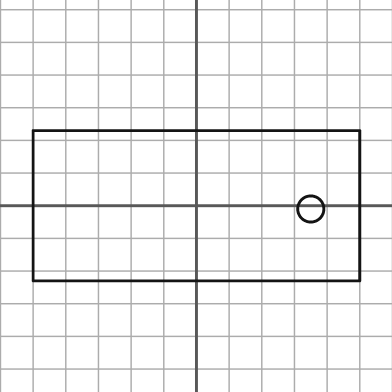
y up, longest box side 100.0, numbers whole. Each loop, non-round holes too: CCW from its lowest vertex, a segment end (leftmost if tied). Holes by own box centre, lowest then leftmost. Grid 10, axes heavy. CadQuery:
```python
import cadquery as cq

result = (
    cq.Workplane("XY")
    .moveTo(-50.0, -23.0)
    .lineTo(50.0, -23.0)
    .lineTo(50.0, 23.0)
    .lineTo(-50.0, 23.0)
    .close()
    .moveTo(35.0, -1.0)
    .circle(4.0)
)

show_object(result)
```